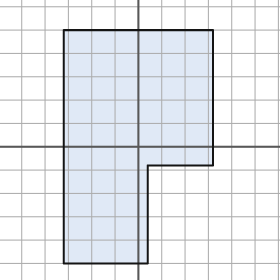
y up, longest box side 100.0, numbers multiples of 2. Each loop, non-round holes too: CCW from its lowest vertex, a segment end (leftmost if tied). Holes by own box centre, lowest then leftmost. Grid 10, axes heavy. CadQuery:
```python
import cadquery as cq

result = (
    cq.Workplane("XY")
    .moveTo(-32.0, -50.0)
    .lineTo(4.0, -50.0)
    .lineTo(4.0, -8.0)
    .lineTo(32.0, -8.0)
    .lineTo(32.0, 50.0)
    .lineTo(-32.0, 50.0)
    .close()
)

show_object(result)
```